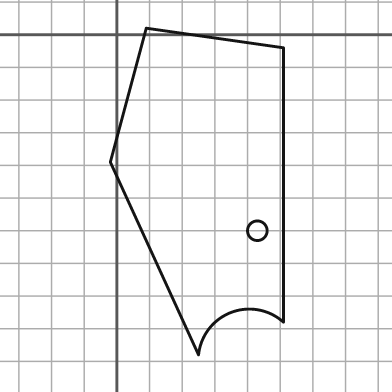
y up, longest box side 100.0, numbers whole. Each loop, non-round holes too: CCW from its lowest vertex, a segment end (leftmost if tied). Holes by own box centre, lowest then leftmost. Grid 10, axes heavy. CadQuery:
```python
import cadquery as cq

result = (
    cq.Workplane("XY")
    .moveTo(25.0, -98.0)
    .threePointArc((35.0, -85.0), (51.0, -88.0))
    .lineTo(51.0, -4.0)
    .lineTo(9.0, 2.0)
    .lineTo(-2.0, -39.0)
    .close()
    .moveTo(43.0, -60.0)
    .circle(3.0)
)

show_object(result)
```